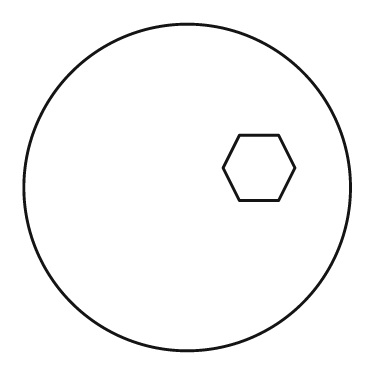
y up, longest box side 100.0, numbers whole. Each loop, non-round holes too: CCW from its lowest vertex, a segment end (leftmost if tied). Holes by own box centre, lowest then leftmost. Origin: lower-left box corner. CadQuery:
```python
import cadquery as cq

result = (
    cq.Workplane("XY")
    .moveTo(50.0, 50.0)
    .circle(50.0)
    .moveTo(66.0, 46.0)
    .lineTo(78.0, 46.0)
    .lineTo(83.0, 56.0)
    .lineTo(78.0, 66.0)
    .lineTo(66.0, 66.0)
    .lineTo(61.0, 56.0)
    .close()
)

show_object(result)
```